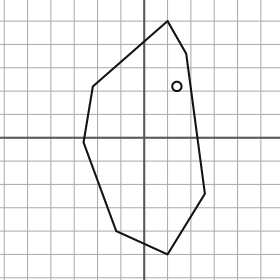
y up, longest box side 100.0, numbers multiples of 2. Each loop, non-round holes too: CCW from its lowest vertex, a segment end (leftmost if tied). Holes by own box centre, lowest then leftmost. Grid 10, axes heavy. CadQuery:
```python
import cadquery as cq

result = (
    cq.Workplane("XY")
    .moveTo(10.0, -50.0)
    .lineTo(26.0, -24.0)
    .lineTo(18.0, 36.0)
    .lineTo(10.0, 50.0)
    .lineTo(-22.0, 22.0)
    .lineTo(-26.0, -2.0)
    .lineTo(-12.0, -40.0)
    .close()
    .moveTo(14.0, 22.0)
    .circle(2.0)
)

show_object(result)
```